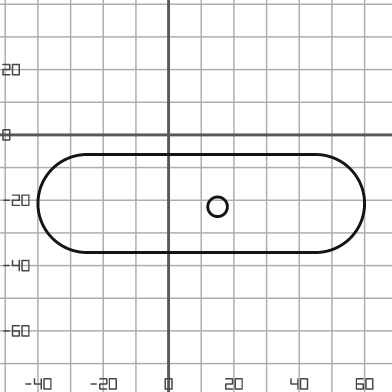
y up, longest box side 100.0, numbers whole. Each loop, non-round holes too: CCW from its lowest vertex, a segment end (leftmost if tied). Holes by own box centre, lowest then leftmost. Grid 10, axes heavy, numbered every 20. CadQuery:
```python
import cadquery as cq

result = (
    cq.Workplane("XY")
    .moveTo(-25.0, -36.0)
    .lineTo(45.0, -36.0)
    .threePointArc((60.0, -21.0), (45.0, -6.0))
    .lineTo(-25.0, -6.0)
    .threePointArc((-40.0, -21.0), (-25.0, -36.0))
    .close()
    .moveTo(15.0, -22.0)
    .circle(3.0)
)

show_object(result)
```